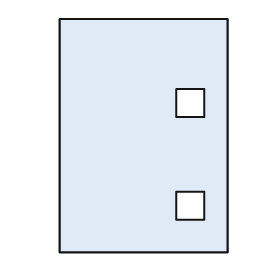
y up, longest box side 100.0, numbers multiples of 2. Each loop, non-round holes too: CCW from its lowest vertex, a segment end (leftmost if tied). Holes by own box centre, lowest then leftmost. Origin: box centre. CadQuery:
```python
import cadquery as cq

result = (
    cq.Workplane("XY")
    .moveTo(-36.0, -50.0)
    .lineTo(36.0, -50.0)
    .lineTo(36.0, 50.0)
    .lineTo(-36.0, 50.0)
    .close()
    .moveTo(14.0, -36.0)
    .lineTo(26.0, -36.0)
    .lineTo(26.0, -24.0)
    .lineTo(14.0, -24.0)
    .close()
    .moveTo(14.0, 8.0)
    .lineTo(26.0, 8.0)
    .lineTo(26.0, 20.0)
    .lineTo(14.0, 20.0)
    .close()
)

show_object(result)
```